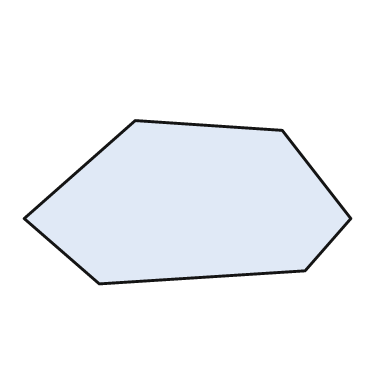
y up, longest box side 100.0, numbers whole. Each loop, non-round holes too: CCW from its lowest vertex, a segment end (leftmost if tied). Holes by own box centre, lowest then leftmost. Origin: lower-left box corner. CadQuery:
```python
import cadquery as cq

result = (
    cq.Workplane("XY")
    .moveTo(23.0, 0.0)
    .lineTo(86.0, 4.0)
    .lineTo(100.0, 20.0)
    .lineTo(79.0, 47.0)
    .lineTo(34.0, 50.0)
    .lineTo(0.0, 20.0)
    .close()
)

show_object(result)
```